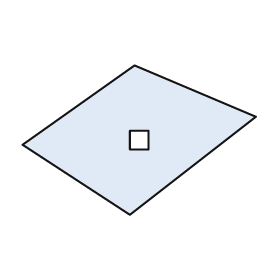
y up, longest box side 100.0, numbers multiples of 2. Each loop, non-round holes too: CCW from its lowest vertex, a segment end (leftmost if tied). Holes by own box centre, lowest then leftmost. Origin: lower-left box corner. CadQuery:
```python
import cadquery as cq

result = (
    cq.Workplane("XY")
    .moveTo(46.0, 0.0)
    .lineTo(100.0, 42.0)
    .lineTo(48.0, 64.0)
    .lineTo(0.0, 30.0)
    .close()
    .moveTo(46.0, 28.0)
    .lineTo(54.0, 28.0)
    .lineTo(54.0, 36.0)
    .lineTo(46.0, 36.0)
    .close()
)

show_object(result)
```